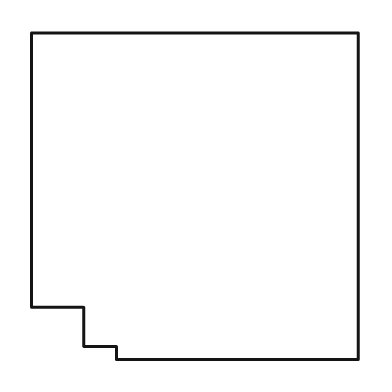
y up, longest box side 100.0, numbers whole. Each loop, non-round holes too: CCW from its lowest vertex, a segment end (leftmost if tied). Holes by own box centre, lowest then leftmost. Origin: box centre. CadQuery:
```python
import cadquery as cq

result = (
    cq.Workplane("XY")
    .moveTo(-24.0, -50.0)
    .lineTo(50.0, -50.0)
    .lineTo(50.0, 50.0)
    .lineTo(-50.0, 50.0)
    .lineTo(-50.0, -34.0)
    .lineTo(-34.0, -34.0)
    .lineTo(-34.0, -46.0)
    .lineTo(-24.0, -46.0)
    .close()
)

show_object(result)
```